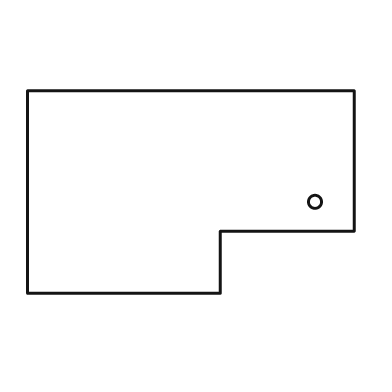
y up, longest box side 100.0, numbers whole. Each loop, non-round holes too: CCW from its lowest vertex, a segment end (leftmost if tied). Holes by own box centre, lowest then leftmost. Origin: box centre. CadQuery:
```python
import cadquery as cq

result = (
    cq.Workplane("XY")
    .moveTo(-50.0, -31.0)
    .lineTo(9.0, -31.0)
    .lineTo(9.0, -12.0)
    .lineTo(50.0, -12.0)
    .lineTo(50.0, 31.0)
    .lineTo(-50.0, 31.0)
    .close()
    .moveTo(38.0, -3.0)
    .circle(2.0)
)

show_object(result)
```